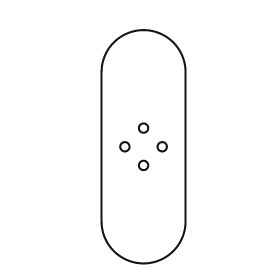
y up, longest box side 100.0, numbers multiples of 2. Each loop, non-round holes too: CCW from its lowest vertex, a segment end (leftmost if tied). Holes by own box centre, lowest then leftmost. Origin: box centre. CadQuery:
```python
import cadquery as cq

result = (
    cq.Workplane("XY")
    .moveTo(-18.0, -32.0)
    .threePointArc((0.0, -50.0), (18.0, -32.0))
    .lineTo(18.0, 32.0)
    .threePointArc((0.0, 50.0), (-18.0, 32.0))
    .close()
    .moveTo(0.0, -8.0)
    .circle(2.0)
    .moveTo(-8.0, 0.0)
    .circle(2.0)
    .moveTo(8.0, 0.0)
    .circle(2.0)
    .moveTo(0.0, 8.0)
    .circle(2.0)
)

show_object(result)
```